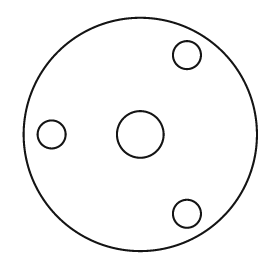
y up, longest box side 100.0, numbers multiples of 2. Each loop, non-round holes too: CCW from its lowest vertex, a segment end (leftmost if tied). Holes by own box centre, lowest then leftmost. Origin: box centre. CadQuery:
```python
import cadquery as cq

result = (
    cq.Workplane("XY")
    .moveTo(0.0, 0.0)
    .circle(50.0)
    .moveTo(20.0, -34.0)
    .circle(6.0)
    .moveTo(-38.0, 0.0)
    .circle(6.0)
    .moveTo(0.0, 0.0)
    .circle(10.0)
    .moveTo(20.0, 34.0)
    .circle(6.0)
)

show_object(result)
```